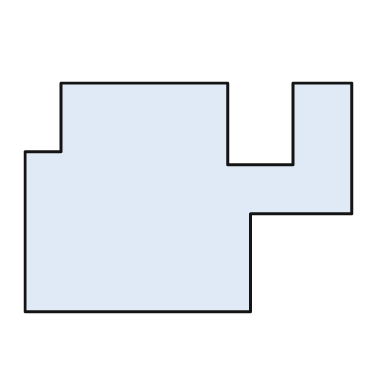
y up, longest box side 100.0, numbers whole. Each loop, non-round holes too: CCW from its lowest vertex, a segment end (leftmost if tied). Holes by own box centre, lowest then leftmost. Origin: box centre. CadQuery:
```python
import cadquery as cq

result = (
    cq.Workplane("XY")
    .moveTo(-50.0, -35.0)
    .lineTo(19.0, -35.0)
    .lineTo(19.0, -5.0)
    .lineTo(50.0, -5.0)
    .lineTo(50.0, 35.0)
    .lineTo(32.0, 35.0)
    .lineTo(32.0, 10.0)
    .lineTo(12.0, 10.0)
    .lineTo(12.0, 35.0)
    .lineTo(-39.0, 35.0)
    .lineTo(-39.0, 14.0)
    .lineTo(-50.0, 14.0)
    .close()
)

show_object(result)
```